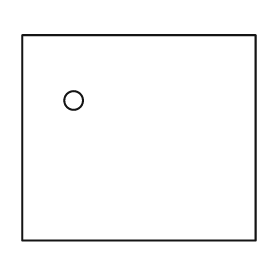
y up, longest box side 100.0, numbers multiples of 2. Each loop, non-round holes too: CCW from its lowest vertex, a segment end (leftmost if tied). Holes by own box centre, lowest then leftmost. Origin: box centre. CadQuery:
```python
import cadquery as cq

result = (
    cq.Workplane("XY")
    .moveTo(-50.0, -44.0)
    .lineTo(50.0, -44.0)
    .lineTo(50.0, 44.0)
    .lineTo(-50.0, 44.0)
    .close()
    .moveTo(-28.0, 16.0)
    .circle(4.0)
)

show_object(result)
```